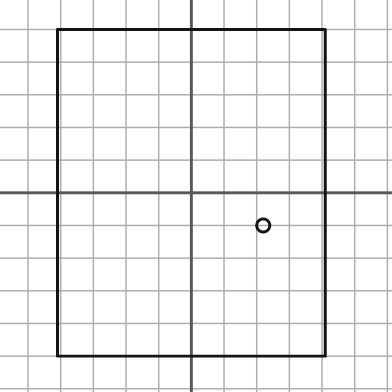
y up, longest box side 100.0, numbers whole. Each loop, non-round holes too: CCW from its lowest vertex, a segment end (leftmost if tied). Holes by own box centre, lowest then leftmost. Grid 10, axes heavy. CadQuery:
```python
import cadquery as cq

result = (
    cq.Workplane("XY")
    .moveTo(-41.0, -50.0)
    .lineTo(41.0, -50.0)
    .lineTo(41.0, 50.0)
    .lineTo(-41.0, 50.0)
    .close()
    .moveTo(22.0, -10.0)
    .circle(2.0)
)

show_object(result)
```